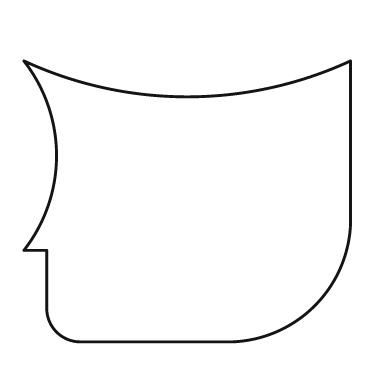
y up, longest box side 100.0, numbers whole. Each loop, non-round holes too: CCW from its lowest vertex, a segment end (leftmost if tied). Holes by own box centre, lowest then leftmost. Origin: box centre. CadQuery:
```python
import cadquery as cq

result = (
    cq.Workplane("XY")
    .moveTo(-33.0, -43.0)
    .lineTo(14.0, -43.0)
    .threePointArc((39.0, -32.0), (50.0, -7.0))
    .lineTo(50.0, 43.0)
    .threePointArc((0.0, 32.0), (-50.0, 43.0))
    .threePointArc((-40.0, 14.0), (-50.0, -15.0))
    .lineTo(-43.0, -15.0)
    .lineTo(-43.0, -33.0)
    .threePointArc((-40.0, -40.0), (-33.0, -43.0))
    .close()
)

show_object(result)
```